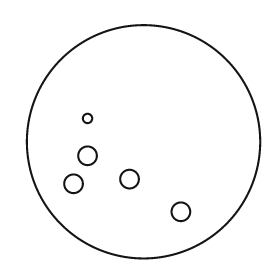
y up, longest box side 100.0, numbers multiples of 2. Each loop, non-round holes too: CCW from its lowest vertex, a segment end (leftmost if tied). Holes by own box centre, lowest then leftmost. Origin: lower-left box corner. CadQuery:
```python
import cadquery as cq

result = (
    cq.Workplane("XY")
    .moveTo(50.0, 50.0)
    .circle(50.0)
    .moveTo(66.0, 20.0)
    .circle(4.0)
    .moveTo(20.0, 32.0)
    .circle(4.0)
    .moveTo(44.0, 34.0)
    .circle(4.0)
    .moveTo(26.0, 44.0)
    .circle(4.0)
    .moveTo(26.0, 60.0)
    .circle(2.0)
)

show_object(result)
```